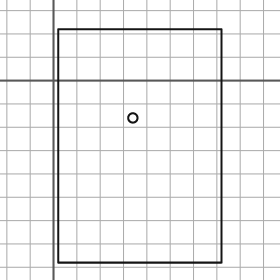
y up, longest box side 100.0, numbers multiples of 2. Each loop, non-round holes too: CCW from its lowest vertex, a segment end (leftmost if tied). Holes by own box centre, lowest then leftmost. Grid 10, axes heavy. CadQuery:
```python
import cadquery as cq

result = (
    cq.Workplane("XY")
    .moveTo(2.0, -78.0)
    .lineTo(72.0, -78.0)
    .lineTo(72.0, 22.0)
    .lineTo(2.0, 22.0)
    .close()
    .moveTo(34.0, -16.0)
    .circle(2.0)
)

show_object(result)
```